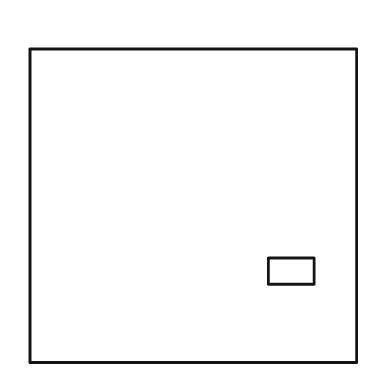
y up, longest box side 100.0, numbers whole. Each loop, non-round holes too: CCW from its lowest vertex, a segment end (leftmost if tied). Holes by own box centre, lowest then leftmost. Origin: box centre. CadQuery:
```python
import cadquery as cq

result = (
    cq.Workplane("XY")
    .moveTo(-50.0, -48.0)
    .lineTo(50.0, -48.0)
    .lineTo(50.0, 48.0)
    .lineTo(-50.0, 48.0)
    .close()
    .moveTo(23.0, -24.0)
    .lineTo(37.0, -24.0)
    .lineTo(37.0, -16.0)
    .lineTo(23.0, -16.0)
    .close()
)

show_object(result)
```